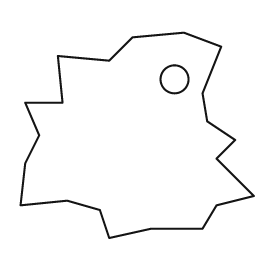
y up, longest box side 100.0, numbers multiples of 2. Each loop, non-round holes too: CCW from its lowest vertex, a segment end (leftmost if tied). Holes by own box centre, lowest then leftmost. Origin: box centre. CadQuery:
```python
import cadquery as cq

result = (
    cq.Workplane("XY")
    .moveTo(-12.0, -44.0)
    .lineTo(6.0, -40.0)
    .lineTo(28.0, -40.0)
    .lineTo(34.0, -30.0)
    .lineTo(50.0, -26.0)
    .lineTo(34.0, -10.0)
    .lineTo(42.0, -2.0)
    .lineTo(30.0, 6.0)
    .lineTo(28.0, 18.0)
    .lineTo(36.0, 38.0)
    .lineTo(20.0, 44.0)
    .lineTo(-2.0, 42.0)
    .lineTo(-12.0, 32.0)
    .lineTo(-34.0, 34.0)
    .lineTo(-32.0, 14.0)
    .lineTo(-48.0, 14.0)
    .lineTo(-42.0, 0.0)
    .lineTo(-48.0, -12.0)
    .lineTo(-50.0, -30.0)
    .lineTo(-30.0, -28.0)
    .lineTo(-16.0, -32.0)
    .close()
    .moveTo(16.0, 24.0)
    .circle(6.0)
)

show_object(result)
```